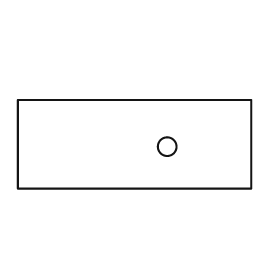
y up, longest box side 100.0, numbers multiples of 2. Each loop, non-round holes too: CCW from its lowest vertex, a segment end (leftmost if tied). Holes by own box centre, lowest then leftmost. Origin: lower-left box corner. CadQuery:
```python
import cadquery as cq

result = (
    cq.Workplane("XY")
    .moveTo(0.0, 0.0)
    .lineTo(100.0, 0.0)
    .lineTo(100.0, 38.0)
    .lineTo(0.0, 38.0)
    .close()
    .moveTo(64.0, 18.0)
    .circle(4.0)
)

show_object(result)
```